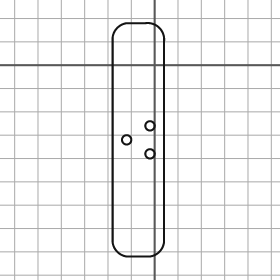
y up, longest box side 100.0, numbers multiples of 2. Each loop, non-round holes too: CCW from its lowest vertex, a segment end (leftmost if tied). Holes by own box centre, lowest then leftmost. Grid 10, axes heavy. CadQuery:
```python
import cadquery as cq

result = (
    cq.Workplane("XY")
    .moveTo(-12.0, -82.0)
    .lineTo(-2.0, -82.0)
    .threePointArc((2.0, -80.0), (4.0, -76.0))
    .lineTo(4.0, 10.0)
    .threePointArc((2.0, 16.0), (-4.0, 18.0))
    .lineTo(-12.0, 18.0)
    .threePointArc((-16.0, 16.0), (-18.0, 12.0))
    .lineTo(-18.0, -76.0)
    .threePointArc((-16.0, -80.0), (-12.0, -82.0))
    .close()
    .moveTo(-2.0, -38.0)
    .circle(2.0)
    .moveTo(-12.0, -32.0)
    .circle(2.0)
    .moveTo(-2.0, -26.0)
    .circle(2.0)
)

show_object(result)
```